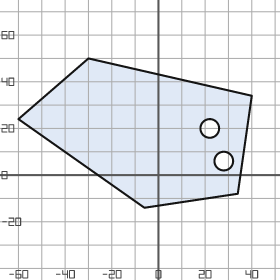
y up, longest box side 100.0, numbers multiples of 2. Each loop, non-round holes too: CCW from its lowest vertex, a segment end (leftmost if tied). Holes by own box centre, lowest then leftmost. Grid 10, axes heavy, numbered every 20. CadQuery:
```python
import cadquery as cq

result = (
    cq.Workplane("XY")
    .moveTo(-6.0, -14.0)
    .lineTo(34.0, -8.0)
    .lineTo(40.0, 34.0)
    .lineTo(-30.0, 50.0)
    .lineTo(-60.0, 24.0)
    .close()
    .moveTo(28.0, 6.0)
    .circle(4.0)
    .moveTo(22.0, 20.0)
    .circle(4.0)
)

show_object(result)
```